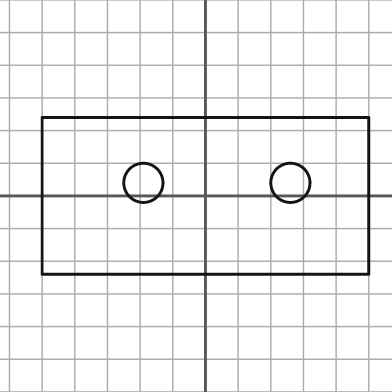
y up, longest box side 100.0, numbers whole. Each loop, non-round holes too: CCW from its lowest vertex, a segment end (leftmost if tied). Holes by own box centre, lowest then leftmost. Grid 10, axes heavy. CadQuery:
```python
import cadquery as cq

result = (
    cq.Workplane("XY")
    .moveTo(-50.0, -24.0)
    .lineTo(50.0, -24.0)
    .lineTo(50.0, 24.0)
    .lineTo(-50.0, 24.0)
    .close()
    .moveTo(-19.0, 4.0)
    .circle(6.0)
    .moveTo(26.0, 4.0)
    .circle(6.0)
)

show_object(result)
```